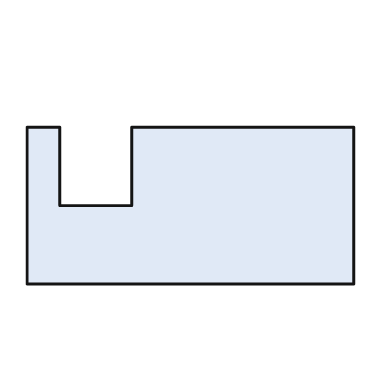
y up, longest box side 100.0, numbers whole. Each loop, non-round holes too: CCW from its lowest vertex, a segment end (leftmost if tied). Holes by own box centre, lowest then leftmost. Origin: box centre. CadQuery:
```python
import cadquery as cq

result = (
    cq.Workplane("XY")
    .moveTo(-50.0, -24.0)
    .lineTo(50.0, -24.0)
    .lineTo(50.0, 24.0)
    .lineTo(-18.0, 24.0)
    .lineTo(-18.0, 0.0)
    .lineTo(-40.0, 0.0)
    .lineTo(-40.0, 24.0)
    .lineTo(-50.0, 24.0)
    .close()
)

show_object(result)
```